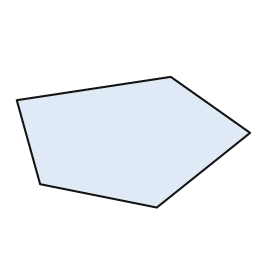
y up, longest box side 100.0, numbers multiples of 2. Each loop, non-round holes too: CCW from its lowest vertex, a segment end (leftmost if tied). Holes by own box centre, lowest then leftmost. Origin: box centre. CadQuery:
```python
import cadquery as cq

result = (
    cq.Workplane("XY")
    .moveTo(10.0, -28.0)
    .lineTo(50.0, 4.0)
    .lineTo(16.0, 28.0)
    .lineTo(-50.0, 18.0)
    .lineTo(-40.0, -18.0)
    .close()
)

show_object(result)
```